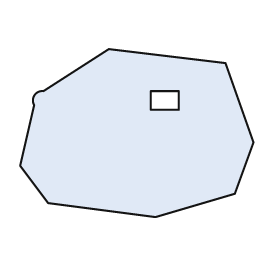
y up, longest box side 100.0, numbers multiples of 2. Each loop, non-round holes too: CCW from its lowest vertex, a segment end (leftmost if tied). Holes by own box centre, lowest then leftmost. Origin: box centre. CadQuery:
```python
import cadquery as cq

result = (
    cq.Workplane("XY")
    .moveTo(8.0, -36.0)
    .lineTo(42.0, -26.0)
    .lineTo(50.0, -4.0)
    .lineTo(38.0, 30.0)
    .lineTo(-12.0, 36.0)
    .lineTo(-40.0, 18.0)
    .threePointArc((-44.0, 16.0), (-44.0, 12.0))
    .lineTo(-50.0, -14.0)
    .lineTo(-38.0, -30.0)
    .close()
    .moveTo(6.0, 10.0)
    .lineTo(18.0, 10.0)
    .lineTo(18.0, 18.0)
    .lineTo(6.0, 18.0)
    .close()
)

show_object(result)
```